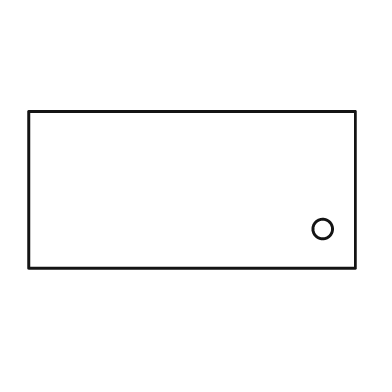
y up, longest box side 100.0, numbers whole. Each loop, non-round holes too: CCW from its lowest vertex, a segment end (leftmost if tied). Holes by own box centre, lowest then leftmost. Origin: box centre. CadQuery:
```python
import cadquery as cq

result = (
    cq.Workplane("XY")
    .moveTo(-50.0, -24.0)
    .lineTo(50.0, -24.0)
    .lineTo(50.0, 24.0)
    .lineTo(-50.0, 24.0)
    .close()
    .moveTo(40.0, -12.0)
    .circle(3.0)
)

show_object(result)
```